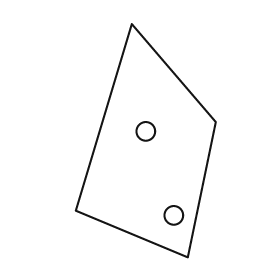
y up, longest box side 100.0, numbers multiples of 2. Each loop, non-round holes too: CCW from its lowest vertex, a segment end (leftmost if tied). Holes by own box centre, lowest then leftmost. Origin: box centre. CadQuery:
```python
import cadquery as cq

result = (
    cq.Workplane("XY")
    .moveTo(18.0, -50.0)
    .lineTo(30.0, 8.0)
    .lineTo(-6.0, 50.0)
    .lineTo(-30.0, -30.0)
    .close()
    .moveTo(12.0, -32.0)
    .circle(4.0)
    .moveTo(0.0, 4.0)
    .circle(4.0)
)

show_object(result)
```